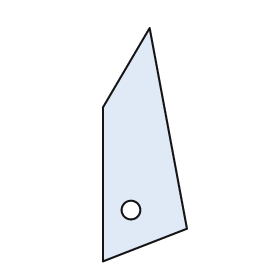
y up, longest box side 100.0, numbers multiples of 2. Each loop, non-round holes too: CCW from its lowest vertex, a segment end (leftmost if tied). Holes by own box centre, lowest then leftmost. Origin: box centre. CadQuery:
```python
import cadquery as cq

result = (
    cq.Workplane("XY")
    .moveTo(-18.0, -50.0)
    .lineTo(18.0, -36.0)
    .lineTo(2.0, 50.0)
    .lineTo(-18.0, 16.0)
    .close()
    .moveTo(-6.0, -28.0)
    .circle(4.0)
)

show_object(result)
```